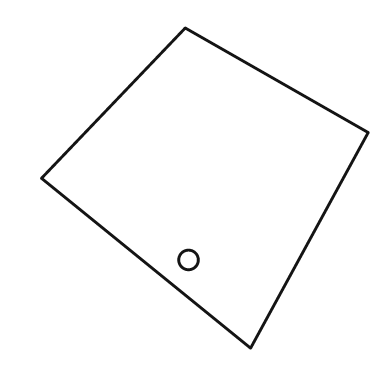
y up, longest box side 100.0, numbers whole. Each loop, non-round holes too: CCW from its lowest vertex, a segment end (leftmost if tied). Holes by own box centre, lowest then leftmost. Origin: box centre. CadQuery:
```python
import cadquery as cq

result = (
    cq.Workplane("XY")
    .moveTo(14.0, -49.0)
    .lineTo(50.0, 17.0)
    .lineTo(-6.0, 49.0)
    .lineTo(-50.0, 3.0)
    .close()
    .moveTo(-5.0, -22.0)
    .circle(3.0)
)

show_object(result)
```